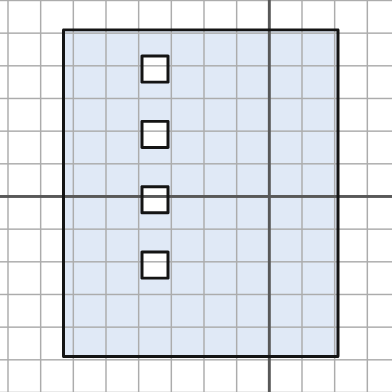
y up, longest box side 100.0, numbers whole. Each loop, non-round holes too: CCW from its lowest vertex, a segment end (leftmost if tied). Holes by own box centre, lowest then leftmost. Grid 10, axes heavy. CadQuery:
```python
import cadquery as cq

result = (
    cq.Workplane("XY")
    .moveTo(-63.0, -49.0)
    .lineTo(21.0, -49.0)
    .lineTo(21.0, 51.0)
    .lineTo(-63.0, 51.0)
    .close()
    .moveTo(-39.0, -25.0)
    .lineTo(-31.0, -25.0)
    .lineTo(-31.0, -17.0)
    .lineTo(-39.0, -17.0)
    .close()
    .moveTo(-39.0, -5.0)
    .lineTo(-31.0, -5.0)
    .lineTo(-31.0, 3.0)
    .lineTo(-39.0, 3.0)
    .close()
    .moveTo(-39.0, 15.0)
    .lineTo(-31.0, 15.0)
    .lineTo(-31.0, 23.0)
    .lineTo(-39.0, 23.0)
    .close()
    .moveTo(-39.0, 35.0)
    .lineTo(-31.0, 35.0)
    .lineTo(-31.0, 43.0)
    .lineTo(-39.0, 43.0)
    .close()
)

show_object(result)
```